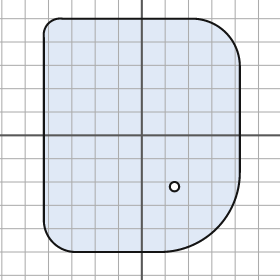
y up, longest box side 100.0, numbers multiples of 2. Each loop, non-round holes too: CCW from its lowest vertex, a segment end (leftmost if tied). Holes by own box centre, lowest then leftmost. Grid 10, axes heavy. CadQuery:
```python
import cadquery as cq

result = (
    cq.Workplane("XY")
    .moveTo(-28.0, -50.0)
    .lineTo(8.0, -50.0)
    .threePointArc((32.0, -40.0), (42.0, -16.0))
    .lineTo(42.0, 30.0)
    .threePointArc((36.0, 44.0), (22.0, 50.0))
    .lineTo(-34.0, 50.0)
    .threePointArc((-40.0, 48.0), (-42.0, 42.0))
    .lineTo(-42.0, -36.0)
    .threePointArc((-38.0, -46.0), (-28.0, -50.0))
    .close()
    .moveTo(14.0, -22.0)
    .circle(2.0)
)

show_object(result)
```